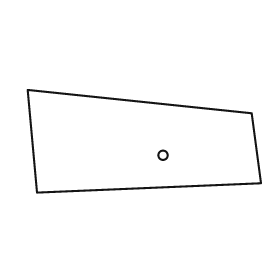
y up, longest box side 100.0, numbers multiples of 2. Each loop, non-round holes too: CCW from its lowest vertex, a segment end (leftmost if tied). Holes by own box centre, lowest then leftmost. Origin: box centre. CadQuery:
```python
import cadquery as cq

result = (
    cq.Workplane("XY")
    .moveTo(-46.0, -22.0)
    .lineTo(50.0, -18.0)
    .lineTo(46.0, 12.0)
    .lineTo(-50.0, 22.0)
    .close()
    .moveTo(8.0, -6.0)
    .circle(2.0)
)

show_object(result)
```